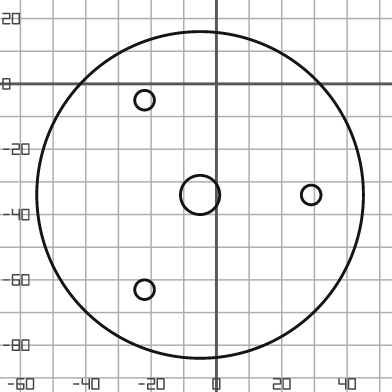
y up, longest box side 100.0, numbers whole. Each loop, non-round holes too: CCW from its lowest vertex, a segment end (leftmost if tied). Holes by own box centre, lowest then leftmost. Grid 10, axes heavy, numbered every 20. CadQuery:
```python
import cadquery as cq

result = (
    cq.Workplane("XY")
    .moveTo(-5.0, -34.0)
    .circle(50.0)
    .moveTo(-22.0, -63.0)
    .circle(3.0)
    .moveTo(-5.0, -34.0)
    .circle(6.0)
    .moveTo(29.0, -34.0)
    .circle(3.0)
    .moveTo(-22.0, -5.0)
    .circle(3.0)
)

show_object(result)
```